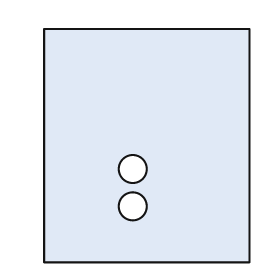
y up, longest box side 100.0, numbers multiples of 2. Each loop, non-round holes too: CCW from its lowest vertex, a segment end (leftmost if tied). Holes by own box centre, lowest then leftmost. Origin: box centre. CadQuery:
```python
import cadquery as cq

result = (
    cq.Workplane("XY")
    .moveTo(-44.0, -50.0)
    .lineTo(44.0, -50.0)
    .lineTo(44.0, 50.0)
    .lineTo(-44.0, 50.0)
    .close()
    .moveTo(-6.0, -26.0)
    .circle(6.0)
    .moveTo(-6.0, -10.0)
    .circle(6.0)
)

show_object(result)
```